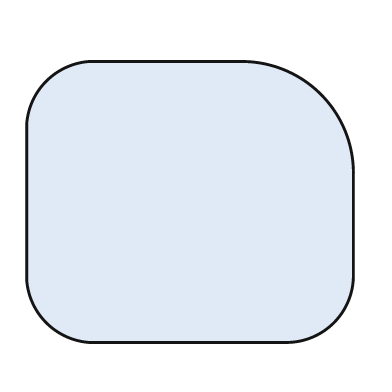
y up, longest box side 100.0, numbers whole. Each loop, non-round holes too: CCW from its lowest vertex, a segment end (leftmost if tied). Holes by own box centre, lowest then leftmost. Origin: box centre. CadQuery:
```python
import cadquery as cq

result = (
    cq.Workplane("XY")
    .moveTo(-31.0, -43.0)
    .lineTo(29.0, -43.0)
    .threePointArc((44.0, -37.0), (50.0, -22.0))
    .lineTo(50.0, 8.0)
    .threePointArc((40.0, 33.0), (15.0, 43.0))
    .lineTo(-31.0, 43.0)
    .threePointArc((-44.0, 37.0), (-50.0, 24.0))
    .lineTo(-50.0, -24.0)
    .threePointArc((-44.0, -37.0), (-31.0, -43.0))
    .close()
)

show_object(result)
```